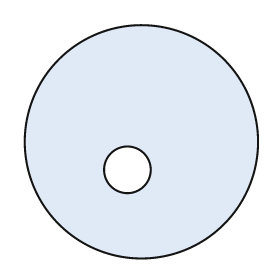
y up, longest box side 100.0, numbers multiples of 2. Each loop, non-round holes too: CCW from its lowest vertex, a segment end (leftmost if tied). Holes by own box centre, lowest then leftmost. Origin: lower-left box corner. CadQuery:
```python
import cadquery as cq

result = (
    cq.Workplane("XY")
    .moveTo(50.0, 50.0)
    .circle(50.0)
    .moveTo(44.0, 38.0)
    .circle(10.0)
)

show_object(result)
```